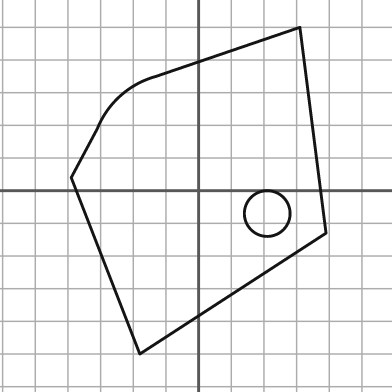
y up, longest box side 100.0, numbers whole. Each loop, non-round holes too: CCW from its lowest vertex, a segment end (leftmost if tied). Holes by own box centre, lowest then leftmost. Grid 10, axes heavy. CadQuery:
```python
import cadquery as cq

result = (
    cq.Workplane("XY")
    .moveTo(-18.0, -50.0)
    .lineTo(39.0, -13.0)
    .lineTo(31.0, 50.0)
    .lineTo(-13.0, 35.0)
    .threePointArc((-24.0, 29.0), (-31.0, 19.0))
    .lineTo(-39.0, 4.0)
    .close()
    .moveTo(21.0, -7.0)
    .circle(7.0)
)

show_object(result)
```